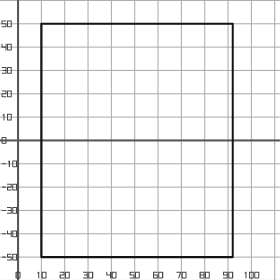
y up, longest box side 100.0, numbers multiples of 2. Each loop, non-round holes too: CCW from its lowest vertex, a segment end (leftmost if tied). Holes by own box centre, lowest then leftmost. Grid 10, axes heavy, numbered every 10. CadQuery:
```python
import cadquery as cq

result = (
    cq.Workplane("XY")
    .moveTo(10.0, -50.0)
    .lineTo(92.0, -50.0)
    .lineTo(92.0, 50.0)
    .lineTo(10.0, 50.0)
    .close()
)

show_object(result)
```